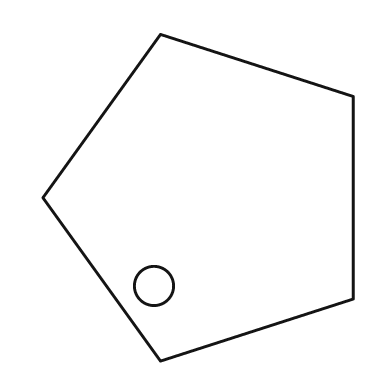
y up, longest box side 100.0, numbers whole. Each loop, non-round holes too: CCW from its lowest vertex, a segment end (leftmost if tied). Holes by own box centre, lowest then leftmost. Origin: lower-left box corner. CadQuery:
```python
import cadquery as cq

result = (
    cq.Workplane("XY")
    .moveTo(36.0, 0.0)
    .lineTo(95.0, 19.0)
    .lineTo(95.0, 81.0)
    .lineTo(36.0, 100.0)
    .lineTo(0.0, 50.0)
    .close()
    .moveTo(34.0, 23.0)
    .circle(6.0)
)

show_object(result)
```